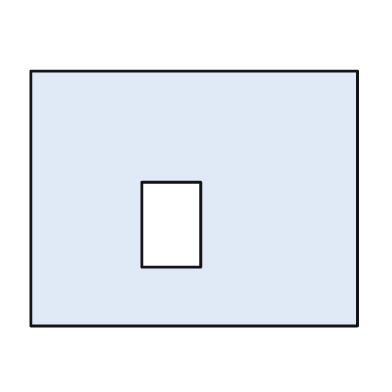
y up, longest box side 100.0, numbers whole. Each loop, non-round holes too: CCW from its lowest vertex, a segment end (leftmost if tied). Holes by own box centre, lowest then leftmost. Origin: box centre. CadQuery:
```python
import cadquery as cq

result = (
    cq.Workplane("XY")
    .moveTo(-50.0, -39.0)
    .lineTo(50.0, -39.0)
    .lineTo(50.0, 39.0)
    .lineTo(-50.0, 39.0)
    .close()
    .moveTo(-16.0, -21.0)
    .lineTo(2.0, -21.0)
    .lineTo(2.0, 5.0)
    .lineTo(-16.0, 5.0)
    .close()
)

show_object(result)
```